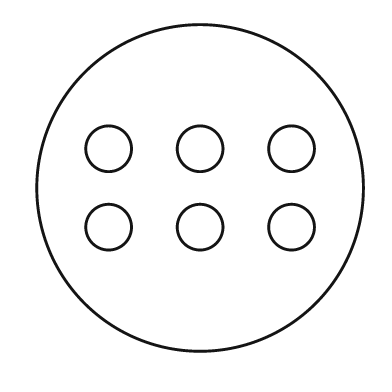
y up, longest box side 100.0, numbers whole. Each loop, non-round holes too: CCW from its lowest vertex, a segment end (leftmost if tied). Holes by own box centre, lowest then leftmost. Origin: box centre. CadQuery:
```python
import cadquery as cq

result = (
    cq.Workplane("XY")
    .moveTo(0.0, 0.0)
    .circle(50.0)
    .moveTo(-28.0, -12.0)
    .circle(7.0)
    .moveTo(0.0, -12.0)
    .circle(7.0)
    .moveTo(28.0, -12.0)
    .circle(7.0)
    .moveTo(-28.0, 12.0)
    .circle(7.0)
    .moveTo(0.0, 12.0)
    .circle(7.0)
    .moveTo(28.0, 12.0)
    .circle(7.0)
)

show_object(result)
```